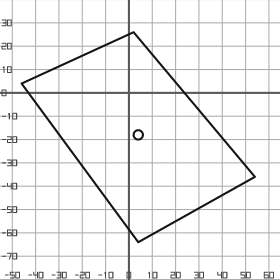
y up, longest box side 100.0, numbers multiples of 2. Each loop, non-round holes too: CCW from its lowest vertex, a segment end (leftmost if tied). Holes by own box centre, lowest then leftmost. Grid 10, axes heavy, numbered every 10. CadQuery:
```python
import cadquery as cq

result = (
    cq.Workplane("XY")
    .moveTo(4.0, -64.0)
    .lineTo(54.0, -36.0)
    .lineTo(2.0, 26.0)
    .lineTo(-46.0, 4.0)
    .close()
    .moveTo(4.0, -18.0)
    .circle(2.0)
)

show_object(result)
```